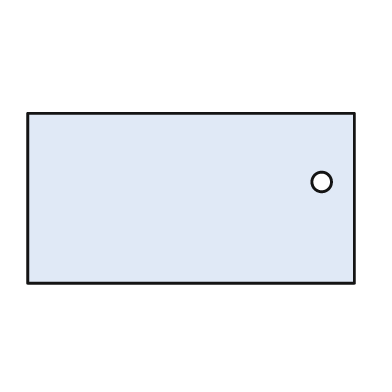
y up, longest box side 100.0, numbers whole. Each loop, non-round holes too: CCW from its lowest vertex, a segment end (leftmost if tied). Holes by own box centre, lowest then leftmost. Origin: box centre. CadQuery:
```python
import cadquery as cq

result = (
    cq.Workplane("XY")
    .moveTo(-50.0, -26.0)
    .lineTo(50.0, -26.0)
    .lineTo(50.0, 26.0)
    .lineTo(-50.0, 26.0)
    .close()
    .moveTo(40.0, 5.0)
    .circle(3.0)
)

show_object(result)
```